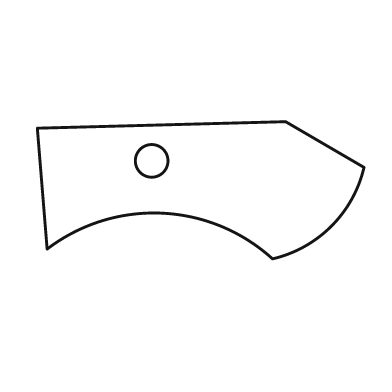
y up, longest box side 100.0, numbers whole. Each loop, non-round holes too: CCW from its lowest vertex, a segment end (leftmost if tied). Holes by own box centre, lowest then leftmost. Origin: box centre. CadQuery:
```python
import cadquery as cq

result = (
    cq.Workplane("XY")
    .moveTo(22.0, -21.0)
    .threePointArc((40.0, -11.0), (50.0, 7.0))
    .lineTo(26.0, 21.0)
    .lineTo(-50.0, 19.0)
    .lineTo(-47.0, -18.0)
    .threePointArc((-12.0, -7.0), (22.0, -21.0))
    .close()
    .moveTo(-15.0, 9.0)
    .circle(5.0)
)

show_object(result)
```